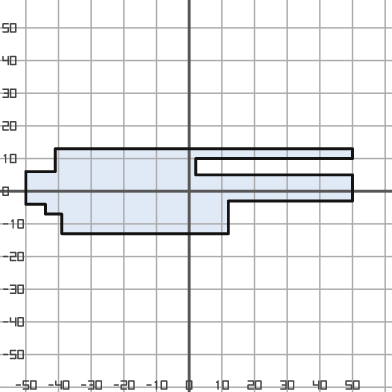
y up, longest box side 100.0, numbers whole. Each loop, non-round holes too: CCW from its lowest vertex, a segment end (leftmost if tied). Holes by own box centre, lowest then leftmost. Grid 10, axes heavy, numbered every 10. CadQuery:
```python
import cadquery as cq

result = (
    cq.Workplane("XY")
    .moveTo(-39.0, -13.0)
    .lineTo(12.0, -13.0)
    .lineTo(12.0, -3.0)
    .lineTo(50.0, -3.0)
    .lineTo(50.0, 5.0)
    .lineTo(2.0, 5.0)
    .lineTo(2.0, 10.0)
    .lineTo(50.0, 10.0)
    .lineTo(50.0, 13.0)
    .lineTo(-41.0, 13.0)
    .lineTo(-41.0, 6.0)
    .lineTo(-50.0, 6.0)
    .lineTo(-50.0, -4.0)
    .lineTo(-44.0, -4.0)
    .lineTo(-44.0, -7.0)
    .lineTo(-39.0, -7.0)
    .close()
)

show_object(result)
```